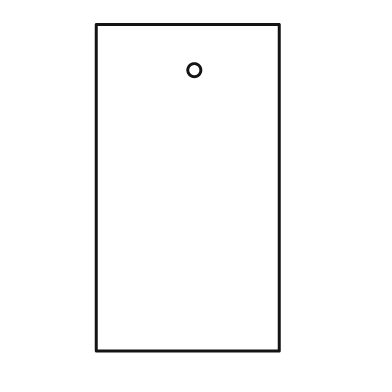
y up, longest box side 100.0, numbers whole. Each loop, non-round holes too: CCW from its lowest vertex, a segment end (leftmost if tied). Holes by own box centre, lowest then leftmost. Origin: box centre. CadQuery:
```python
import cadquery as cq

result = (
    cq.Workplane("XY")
    .moveTo(-28.0, -50.0)
    .lineTo(28.0, -50.0)
    .lineTo(28.0, 50.0)
    .lineTo(-28.0, 50.0)
    .close()
    .moveTo(2.0, 36.0)
    .circle(2.0)
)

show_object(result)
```